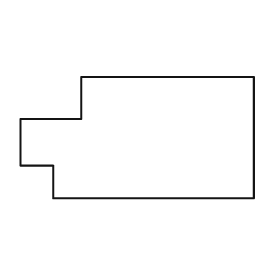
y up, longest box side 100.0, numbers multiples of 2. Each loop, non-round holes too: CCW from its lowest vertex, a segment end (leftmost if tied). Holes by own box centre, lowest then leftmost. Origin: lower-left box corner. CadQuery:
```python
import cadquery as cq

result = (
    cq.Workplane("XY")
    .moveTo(14.0, 0.0)
    .lineTo(100.0, 0.0)
    .lineTo(100.0, 52.0)
    .lineTo(26.0, 52.0)
    .lineTo(26.0, 34.0)
    .lineTo(0.0, 34.0)
    .lineTo(0.0, 14.0)
    .lineTo(14.0, 14.0)
    .close()
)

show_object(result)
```